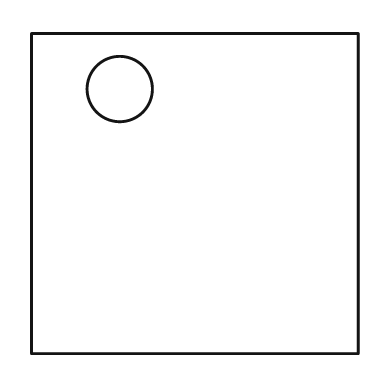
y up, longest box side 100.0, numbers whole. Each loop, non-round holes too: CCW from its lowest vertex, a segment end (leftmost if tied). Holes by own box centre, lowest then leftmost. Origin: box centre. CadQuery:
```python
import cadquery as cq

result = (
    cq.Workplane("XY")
    .moveTo(-50.0, -49.0)
    .lineTo(50.0, -49.0)
    .lineTo(50.0, 49.0)
    .lineTo(-50.0, 49.0)
    .close()
    .moveTo(-23.0, 32.0)
    .circle(10.0)
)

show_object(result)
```